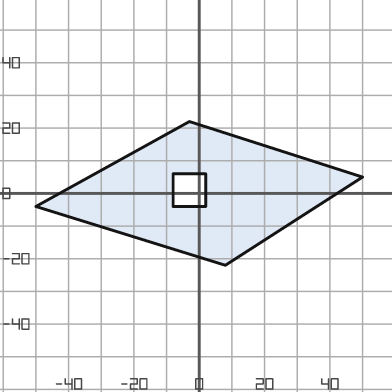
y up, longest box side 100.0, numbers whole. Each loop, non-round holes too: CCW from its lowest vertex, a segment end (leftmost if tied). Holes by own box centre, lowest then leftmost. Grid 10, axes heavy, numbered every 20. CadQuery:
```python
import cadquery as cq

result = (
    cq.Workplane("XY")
    .moveTo(8.0, -22.0)
    .lineTo(50.0, 5.0)
    .lineTo(-3.0, 22.0)
    .lineTo(-50.0, -4.0)
    .close()
    .moveTo(-8.0, -4.0)
    .lineTo(2.0, -4.0)
    .lineTo(2.0, 6.0)
    .lineTo(-8.0, 6.0)
    .close()
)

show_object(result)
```